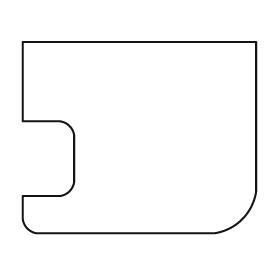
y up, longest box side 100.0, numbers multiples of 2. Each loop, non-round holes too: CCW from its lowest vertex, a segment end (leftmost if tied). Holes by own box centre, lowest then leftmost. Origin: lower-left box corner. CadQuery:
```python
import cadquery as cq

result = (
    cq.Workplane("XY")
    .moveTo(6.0, 0.0)
    .lineTo(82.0, 0.0)
    .threePointArc((94.0, 6.0), (100.0, 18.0))
    .lineTo(100.0, 82.0)
    .lineTo(0.0, 82.0)
    .lineTo(0.0, 48.0)
    .lineTo(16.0, 48.0)
    .threePointArc((20.0, 46.0), (22.0, 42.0))
    .lineTo(22.0, 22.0)
    .threePointArc((20.0, 18.0), (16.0, 16.0))
    .lineTo(0.0, 16.0)
    .lineTo(0.0, 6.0)
    .threePointArc((2.0, 2.0), (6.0, 0.0))
    .close()
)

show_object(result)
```